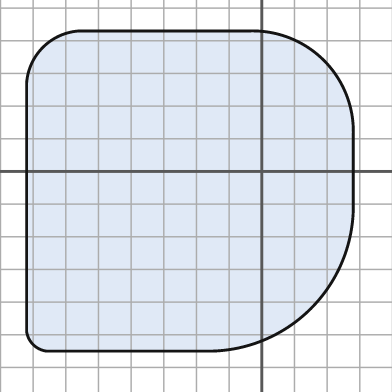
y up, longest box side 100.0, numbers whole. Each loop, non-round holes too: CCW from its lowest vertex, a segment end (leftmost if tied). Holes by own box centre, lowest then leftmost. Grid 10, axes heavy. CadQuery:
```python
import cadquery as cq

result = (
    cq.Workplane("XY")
    .moveTo(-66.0, -55.0)
    .lineTo(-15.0, -55.0)
    .threePointArc((15.0, -42.0), (28.0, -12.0))
    .lineTo(28.0, 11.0)
    .threePointArc((19.0, 34.0), (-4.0, 43.0))
    .lineTo(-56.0, 43.0)
    .threePointArc((-67.0, 38.0), (-72.0, 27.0))
    .lineTo(-72.0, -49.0)
    .threePointArc((-70.0, -53.0), (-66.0, -55.0))
    .close()
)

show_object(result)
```